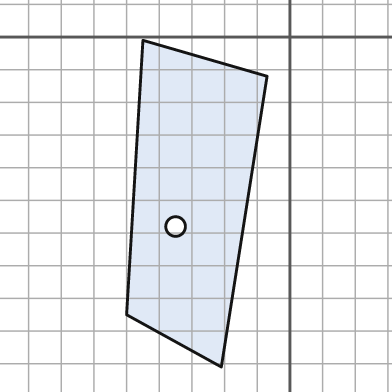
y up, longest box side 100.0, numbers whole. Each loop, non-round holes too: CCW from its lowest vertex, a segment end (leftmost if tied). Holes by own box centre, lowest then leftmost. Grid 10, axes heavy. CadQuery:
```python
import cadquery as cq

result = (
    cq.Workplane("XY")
    .moveTo(-21.0, -101.0)
    .lineTo(-7.0, -12.0)
    .lineTo(-45.0, -1.0)
    .lineTo(-50.0, -85.0)
    .close()
    .moveTo(-35.0, -58.0)
    .circle(3.0)
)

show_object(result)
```